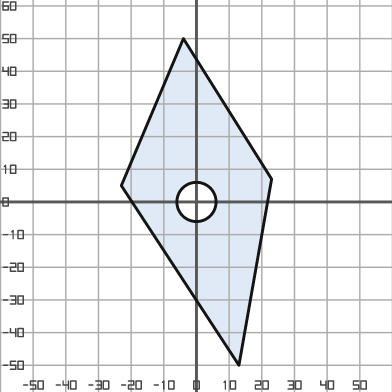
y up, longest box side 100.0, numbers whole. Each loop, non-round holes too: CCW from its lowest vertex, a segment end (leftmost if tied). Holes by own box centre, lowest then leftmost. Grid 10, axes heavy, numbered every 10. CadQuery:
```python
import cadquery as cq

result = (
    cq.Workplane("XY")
    .moveTo(13.0, -50.0)
    .lineTo(23.0, 7.0)
    .lineTo(-4.0, 50.0)
    .lineTo(-23.0, 5.0)
    .close()
    .moveTo(0.0, 0.0)
    .circle(6.0)
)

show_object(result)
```